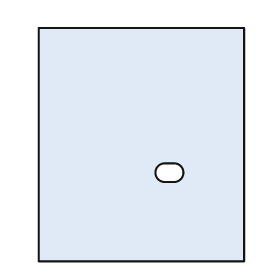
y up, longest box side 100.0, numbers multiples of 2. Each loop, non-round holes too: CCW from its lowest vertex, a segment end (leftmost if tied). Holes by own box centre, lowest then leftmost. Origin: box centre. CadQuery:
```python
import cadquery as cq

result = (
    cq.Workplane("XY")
    .moveTo(-44.0, -50.0)
    .lineTo(44.0, -50.0)
    .lineTo(44.0, 50.0)
    .lineTo(-44.0, 50.0)
    .close()
    .moveTo(10.0, -16.0)
    .lineTo(14.0, -16.0)
    .threePointArc((18.0, -12.0), (14.0, -8.0))
    .lineTo(10.0, -8.0)
    .threePointArc((6.0, -12.0), (10.0, -16.0))
    .close()
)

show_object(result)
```